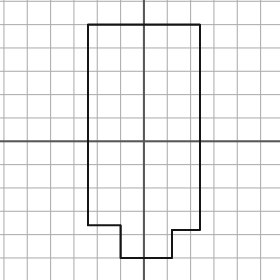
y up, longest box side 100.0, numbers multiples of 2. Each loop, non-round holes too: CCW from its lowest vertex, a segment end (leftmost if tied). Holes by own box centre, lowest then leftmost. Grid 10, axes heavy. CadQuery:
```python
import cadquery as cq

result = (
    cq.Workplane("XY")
    .moveTo(-10.0, -50.0)
    .lineTo(12.0, -50.0)
    .lineTo(12.0, -38.0)
    .lineTo(24.0, -38.0)
    .lineTo(24.0, 50.0)
    .lineTo(-24.0, 50.0)
    .lineTo(-24.0, -36.0)
    .lineTo(-10.0, -36.0)
    .close()
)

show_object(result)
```